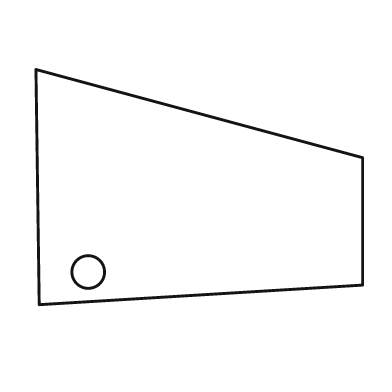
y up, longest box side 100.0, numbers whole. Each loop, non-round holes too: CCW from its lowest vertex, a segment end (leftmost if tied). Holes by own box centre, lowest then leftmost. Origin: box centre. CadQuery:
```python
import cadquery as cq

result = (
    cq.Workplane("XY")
    .moveTo(-49.0, -36.0)
    .lineTo(50.0, -30.0)
    .lineTo(50.0, 9.0)
    .lineTo(-50.0, 36.0)
    .close()
    .moveTo(-34.0, -26.0)
    .circle(5.0)
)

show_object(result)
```